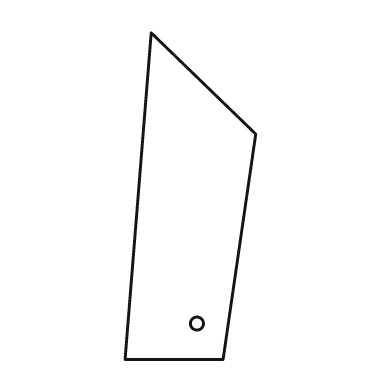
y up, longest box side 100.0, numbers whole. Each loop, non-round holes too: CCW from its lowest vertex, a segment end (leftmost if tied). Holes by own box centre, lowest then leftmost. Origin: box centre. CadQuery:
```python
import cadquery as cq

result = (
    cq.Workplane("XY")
    .moveTo(-20.0, -50.0)
    .lineTo(10.0, -50.0)
    .lineTo(20.0, 19.0)
    .lineTo(-12.0, 50.0)
    .close()
    .moveTo(2.0, -39.0)
    .circle(2.0)
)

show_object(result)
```